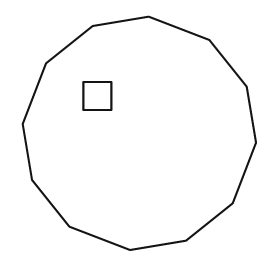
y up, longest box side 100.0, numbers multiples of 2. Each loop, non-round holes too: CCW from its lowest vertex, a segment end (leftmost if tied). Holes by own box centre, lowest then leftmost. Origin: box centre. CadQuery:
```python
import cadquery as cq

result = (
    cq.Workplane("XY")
    .moveTo(-4.0, -50.0)
    .lineTo(20.0, -46.0)
    .lineTo(40.0, -30.0)
    .lineTo(50.0, -4.0)
    .lineTo(46.0, 20.0)
    .lineTo(30.0, 40.0)
    .lineTo(4.0, 50.0)
    .lineTo(-20.0, 46.0)
    .lineTo(-40.0, 30.0)
    .lineTo(-50.0, 4.0)
    .lineTo(-46.0, -20.0)
    .lineTo(-30.0, -40.0)
    .close()
    .moveTo(-24.0, 10.0)
    .lineTo(-12.0, 10.0)
    .lineTo(-12.0, 22.0)
    .lineTo(-24.0, 22.0)
    .close()
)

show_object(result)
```